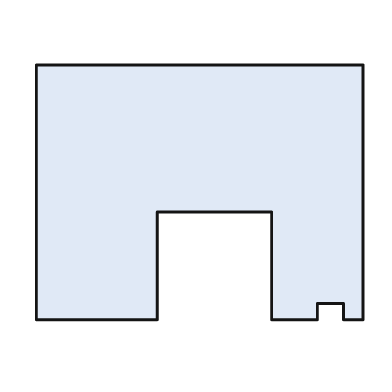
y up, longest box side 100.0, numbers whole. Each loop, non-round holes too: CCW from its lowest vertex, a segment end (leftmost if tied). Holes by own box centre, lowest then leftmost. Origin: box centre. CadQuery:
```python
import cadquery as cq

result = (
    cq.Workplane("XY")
    .moveTo(-50.0, -39.0)
    .lineTo(-13.0, -39.0)
    .lineTo(-13.0, -6.0)
    .lineTo(22.0, -6.0)
    .lineTo(22.0, -39.0)
    .lineTo(36.0, -39.0)
    .lineTo(36.0, -34.0)
    .lineTo(44.0, -34.0)
    .lineTo(44.0, -39.0)
    .lineTo(50.0, -39.0)
    .lineTo(50.0, 39.0)
    .lineTo(-50.0, 39.0)
    .close()
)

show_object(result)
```